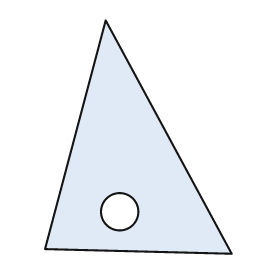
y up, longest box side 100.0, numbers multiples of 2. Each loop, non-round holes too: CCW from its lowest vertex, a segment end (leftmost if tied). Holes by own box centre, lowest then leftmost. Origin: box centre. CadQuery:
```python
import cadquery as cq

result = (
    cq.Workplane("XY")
    .moveTo(40.0, -50.0)
    .lineTo(-14.0, 50.0)
    .lineTo(-40.0, -48.0)
    .close()
    .moveTo(-8.0, -32.0)
    .circle(8.0)
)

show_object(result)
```